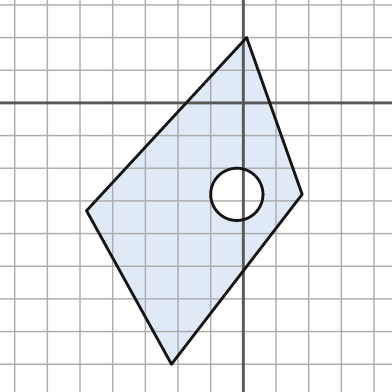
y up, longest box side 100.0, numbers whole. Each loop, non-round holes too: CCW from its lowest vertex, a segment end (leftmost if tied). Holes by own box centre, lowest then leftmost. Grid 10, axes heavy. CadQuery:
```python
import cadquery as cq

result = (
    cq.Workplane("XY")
    .moveTo(-22.0, -80.0)
    .lineTo(18.0, -28.0)
    .lineTo(1.0, 20.0)
    .lineTo(-48.0, -33.0)
    .close()
    .moveTo(-2.0, -28.0)
    .circle(8.0)
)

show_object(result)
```